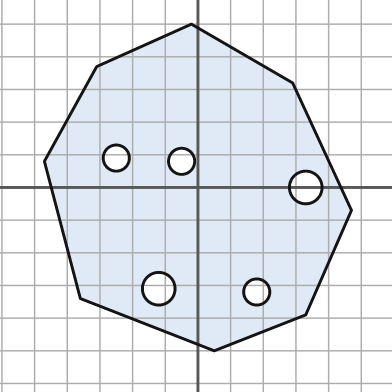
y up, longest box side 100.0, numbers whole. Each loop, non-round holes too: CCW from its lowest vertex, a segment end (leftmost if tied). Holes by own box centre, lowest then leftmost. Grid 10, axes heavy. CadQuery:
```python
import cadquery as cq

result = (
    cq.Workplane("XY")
    .moveTo(5.0, -50.0)
    .lineTo(33.0, -39.0)
    .lineTo(47.0, -7.0)
    .lineTo(29.0, 32.0)
    .lineTo(-2.0, 50.0)
    .lineTo(-31.0, 37.0)
    .lineTo(-47.0, 8.0)
    .lineTo(-36.0, -34.0)
    .close()
    .moveTo(18.0, -32.0)
    .circle(4.0)
    .moveTo(-12.0, -31.0)
    .circle(5.0)
    .moveTo(33.0, 0.0)
    .circle(5.0)
    .moveTo(-5.0, 8.0)
    .circle(4.0)
    .moveTo(-25.0, 9.0)
    .circle(4.0)
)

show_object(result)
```